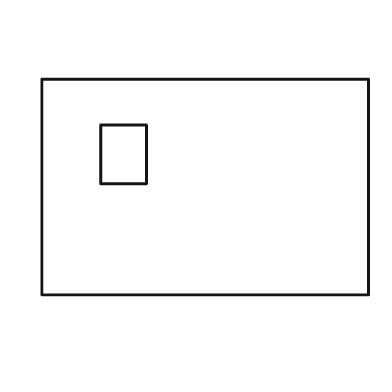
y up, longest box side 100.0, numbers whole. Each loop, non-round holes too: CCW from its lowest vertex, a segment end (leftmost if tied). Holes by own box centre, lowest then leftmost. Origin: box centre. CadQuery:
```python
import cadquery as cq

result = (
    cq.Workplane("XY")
    .moveTo(-50.0, -33.0)
    .lineTo(50.0, -33.0)
    .lineTo(50.0, 33.0)
    .lineTo(-50.0, 33.0)
    .close()
    .moveTo(-32.0, 1.0)
    .lineTo(-18.0, 1.0)
    .lineTo(-18.0, 19.0)
    .lineTo(-32.0, 19.0)
    .close()
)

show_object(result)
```